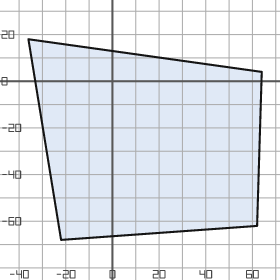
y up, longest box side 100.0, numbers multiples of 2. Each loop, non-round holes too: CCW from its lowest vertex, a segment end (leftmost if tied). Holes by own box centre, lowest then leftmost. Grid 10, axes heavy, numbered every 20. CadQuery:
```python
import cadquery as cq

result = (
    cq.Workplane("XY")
    .moveTo(-22.0, -68.0)
    .lineTo(62.0, -62.0)
    .lineTo(64.0, 4.0)
    .lineTo(-36.0, 18.0)
    .close()
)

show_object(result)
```